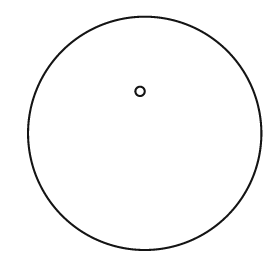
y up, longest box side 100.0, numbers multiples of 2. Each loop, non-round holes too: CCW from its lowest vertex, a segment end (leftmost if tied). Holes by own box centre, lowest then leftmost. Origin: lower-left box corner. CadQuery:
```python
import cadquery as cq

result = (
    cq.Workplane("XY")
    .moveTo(50.0, 50.0)
    .circle(50.0)
    .moveTo(48.0, 68.0)
    .circle(2.0)
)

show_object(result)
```